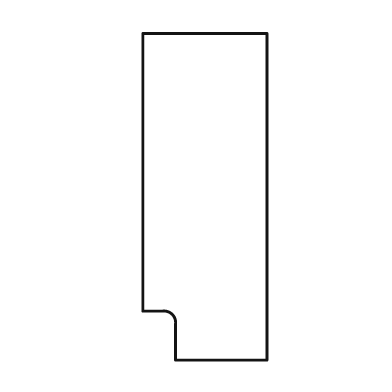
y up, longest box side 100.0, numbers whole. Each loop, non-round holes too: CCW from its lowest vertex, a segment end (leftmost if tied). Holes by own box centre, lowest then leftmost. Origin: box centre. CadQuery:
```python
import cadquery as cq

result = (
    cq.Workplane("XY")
    .moveTo(-9.0, -50.0)
    .lineTo(19.0, -50.0)
    .lineTo(19.0, 50.0)
    .lineTo(-19.0, 50.0)
    .lineTo(-19.0, -35.0)
    .lineTo(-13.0, -35.0)
    .threePointArc((-10.0, -36.0), (-9.0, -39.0))
    .close()
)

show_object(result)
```